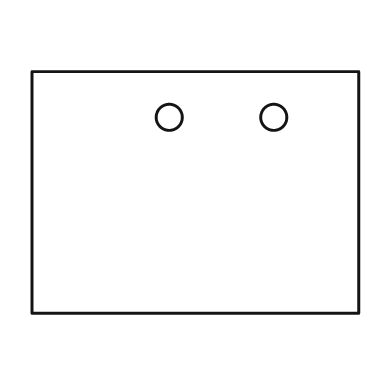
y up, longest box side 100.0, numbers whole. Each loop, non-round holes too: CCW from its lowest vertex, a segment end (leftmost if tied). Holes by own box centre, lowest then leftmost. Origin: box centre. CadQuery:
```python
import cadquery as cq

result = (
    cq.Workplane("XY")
    .moveTo(-50.0, -37.0)
    .lineTo(50.0, -37.0)
    .lineTo(50.0, 37.0)
    .lineTo(-50.0, 37.0)
    .close()
    .moveTo(-8.0, 23.0)
    .circle(4.0)
    .moveTo(24.0, 23.0)
    .circle(4.0)
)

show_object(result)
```